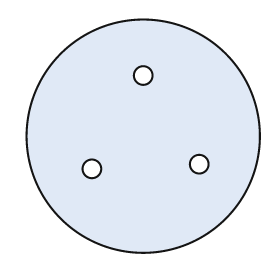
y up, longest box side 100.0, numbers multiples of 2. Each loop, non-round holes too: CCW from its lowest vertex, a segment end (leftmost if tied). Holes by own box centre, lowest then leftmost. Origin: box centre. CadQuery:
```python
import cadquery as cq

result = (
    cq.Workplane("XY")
    .moveTo(0.0, 0.0)
    .circle(50.0)
    .moveTo(-22.0, -14.0)
    .circle(4.0)
    .moveTo(24.0, -12.0)
    .circle(4.0)
    .moveTo(0.0, 26.0)
    .circle(4.0)
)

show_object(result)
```